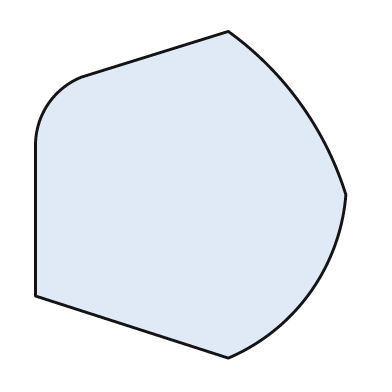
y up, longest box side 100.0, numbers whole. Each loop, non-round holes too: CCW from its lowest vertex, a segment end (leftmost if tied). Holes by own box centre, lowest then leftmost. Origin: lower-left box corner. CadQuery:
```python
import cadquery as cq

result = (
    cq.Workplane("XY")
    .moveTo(59.0, 0.0)
    .threePointArc((84.0, 20.0), (95.0, 50.0))
    .threePointArc((81.0, 78.0), (59.0, 100.0))
    .lineTo(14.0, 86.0)
    .threePointArc((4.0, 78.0), (0.0, 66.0))
    .lineTo(0.0, 19.0)
    .close()
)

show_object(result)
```